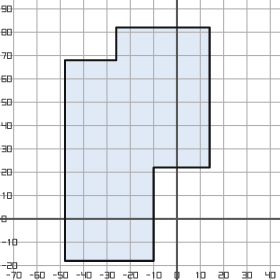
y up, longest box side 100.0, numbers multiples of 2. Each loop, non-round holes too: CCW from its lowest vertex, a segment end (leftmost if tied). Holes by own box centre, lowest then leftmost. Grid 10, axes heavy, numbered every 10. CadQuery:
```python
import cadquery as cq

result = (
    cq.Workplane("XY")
    .moveTo(-48.0, -18.0)
    .lineTo(-10.0, -18.0)
    .lineTo(-10.0, 22.0)
    .lineTo(14.0, 22.0)
    .lineTo(14.0, 82.0)
    .lineTo(-26.0, 82.0)
    .lineTo(-26.0, 68.0)
    .lineTo(-48.0, 68.0)
    .close()
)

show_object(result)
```